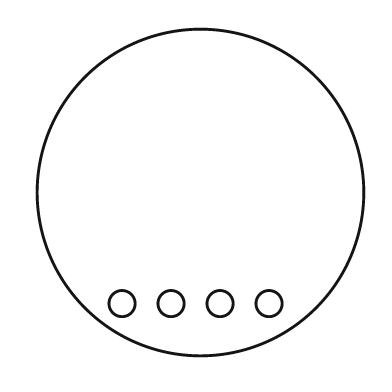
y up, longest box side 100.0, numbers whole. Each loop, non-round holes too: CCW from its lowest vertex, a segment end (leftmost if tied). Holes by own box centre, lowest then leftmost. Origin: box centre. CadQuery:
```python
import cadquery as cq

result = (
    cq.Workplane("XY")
    .moveTo(0.0, 0.0)
    .circle(50.0)
    .moveTo(-24.0, -34.0)
    .circle(4.0)
    .moveTo(-9.0, -34.0)
    .circle(4.0)
    .moveTo(6.0, -34.0)
    .circle(4.0)
    .moveTo(21.0, -34.0)
    .circle(4.0)
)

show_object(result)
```